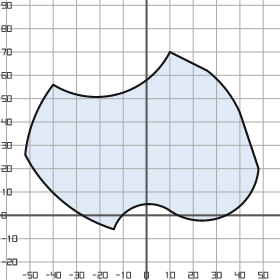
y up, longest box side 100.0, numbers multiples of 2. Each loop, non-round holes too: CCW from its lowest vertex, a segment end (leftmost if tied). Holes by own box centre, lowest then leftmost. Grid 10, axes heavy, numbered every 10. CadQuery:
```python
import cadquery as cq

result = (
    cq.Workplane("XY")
    .moveTo(-14.0, -6.0)
    .threePointArc((-4.0, 4.0), (10.0, 2.0))
    .threePointArc((34.0, 0.0), (48.0, 20.0))
    .lineTo(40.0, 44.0)
    .threePointArc((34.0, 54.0), (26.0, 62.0))
    .lineTo(10.0, 70.0)
    .threePointArc((-12.0, 52.0), (-40.0, 56.0))
    .threePointArc((-48.0, 42.0), (-52.0, 26.0))
    .threePointArc((-36.0, 6.0), (-14.0, -6.0))
    .close()
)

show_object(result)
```